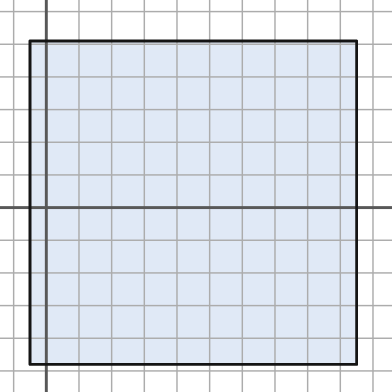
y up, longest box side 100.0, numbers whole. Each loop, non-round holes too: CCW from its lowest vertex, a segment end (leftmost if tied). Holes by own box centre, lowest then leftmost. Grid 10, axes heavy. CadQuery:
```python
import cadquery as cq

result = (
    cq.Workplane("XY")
    .moveTo(-5.0, -48.0)
    .lineTo(95.0, -48.0)
    .lineTo(95.0, 51.0)
    .lineTo(-5.0, 51.0)
    .close()
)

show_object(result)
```